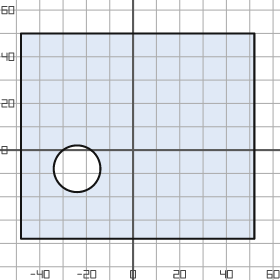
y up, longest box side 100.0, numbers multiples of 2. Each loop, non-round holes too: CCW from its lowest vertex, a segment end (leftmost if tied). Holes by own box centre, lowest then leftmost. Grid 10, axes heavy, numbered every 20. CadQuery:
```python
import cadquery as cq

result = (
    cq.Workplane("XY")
    .moveTo(-48.0, -38.0)
    .lineTo(52.0, -38.0)
    .lineTo(52.0, 50.0)
    .lineTo(-48.0, 50.0)
    .close()
    .moveTo(-24.0, -8.0)
    .circle(10.0)
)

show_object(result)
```